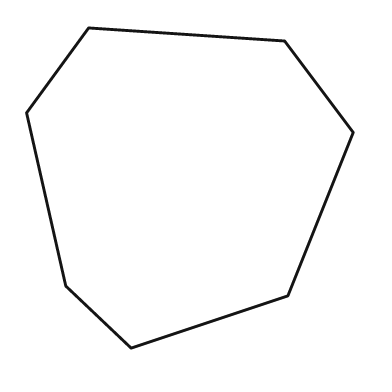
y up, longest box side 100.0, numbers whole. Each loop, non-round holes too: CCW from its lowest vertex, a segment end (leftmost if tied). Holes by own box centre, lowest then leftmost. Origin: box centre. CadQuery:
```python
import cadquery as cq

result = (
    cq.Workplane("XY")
    .moveTo(-18.0, -49.0)
    .lineTo(30.0, -33.0)
    .lineTo(50.0, 17.0)
    .lineTo(29.0, 45.0)
    .lineTo(-31.0, 49.0)
    .lineTo(-50.0, 23.0)
    .lineTo(-38.0, -30.0)
    .close()
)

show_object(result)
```